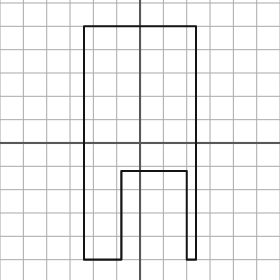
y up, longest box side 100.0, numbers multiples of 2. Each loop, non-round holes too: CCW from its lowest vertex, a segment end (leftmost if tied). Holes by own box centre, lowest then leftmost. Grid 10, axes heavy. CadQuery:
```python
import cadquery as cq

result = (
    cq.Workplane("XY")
    .moveTo(-24.0, -50.0)
    .lineTo(-8.0, -50.0)
    .lineTo(-8.0, -12.0)
    .lineTo(20.0, -12.0)
    .lineTo(20.0, -50.0)
    .lineTo(24.0, -50.0)
    .lineTo(24.0, 50.0)
    .lineTo(-24.0, 50.0)
    .close()
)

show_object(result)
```